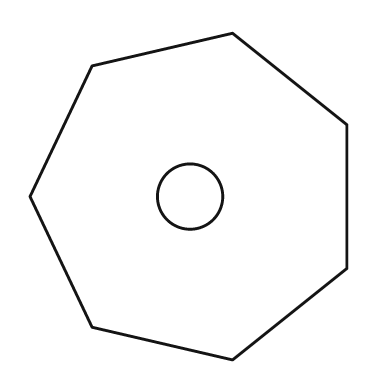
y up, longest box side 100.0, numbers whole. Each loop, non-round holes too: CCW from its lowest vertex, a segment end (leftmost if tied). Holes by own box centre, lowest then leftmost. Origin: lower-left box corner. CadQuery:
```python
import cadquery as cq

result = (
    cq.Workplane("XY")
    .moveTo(62.0, 0.0)
    .lineTo(97.0, 28.0)
    .lineTo(97.0, 72.0)
    .lineTo(62.0, 100.0)
    .lineTo(19.0, 90.0)
    .lineTo(0.0, 50.0)
    .lineTo(19.0, 10.0)
    .close()
    .moveTo(49.0, 50.0)
    .circle(10.0)
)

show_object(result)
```